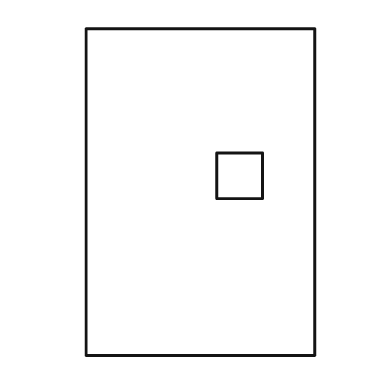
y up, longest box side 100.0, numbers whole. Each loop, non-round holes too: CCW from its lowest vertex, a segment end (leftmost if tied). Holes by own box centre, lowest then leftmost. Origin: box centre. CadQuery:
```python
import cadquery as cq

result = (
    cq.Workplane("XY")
    .moveTo(-35.0, -50.0)
    .lineTo(35.0, -50.0)
    .lineTo(35.0, 50.0)
    .lineTo(-35.0, 50.0)
    .close()
    .moveTo(5.0, -2.0)
    .lineTo(19.0, -2.0)
    .lineTo(19.0, 12.0)
    .lineTo(5.0, 12.0)
    .close()
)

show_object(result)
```